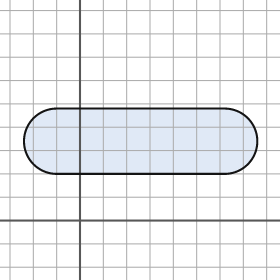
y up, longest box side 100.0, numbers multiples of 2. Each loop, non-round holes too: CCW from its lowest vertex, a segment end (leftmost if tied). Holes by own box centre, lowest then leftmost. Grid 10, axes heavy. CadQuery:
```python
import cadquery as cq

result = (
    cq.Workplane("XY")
    .moveTo(-10.0, 20.0)
    .lineTo(62.0, 20.0)
    .threePointArc((76.0, 34.0), (62.0, 48.0))
    .lineTo(-10.0, 48.0)
    .threePointArc((-24.0, 34.0), (-10.0, 20.0))
    .close()
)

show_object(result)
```